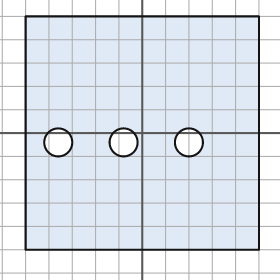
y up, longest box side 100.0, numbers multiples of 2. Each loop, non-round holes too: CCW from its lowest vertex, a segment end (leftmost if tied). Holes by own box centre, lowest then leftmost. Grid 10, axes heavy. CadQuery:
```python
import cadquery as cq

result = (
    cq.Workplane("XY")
    .moveTo(-50.0, -50.0)
    .lineTo(50.0, -50.0)
    .lineTo(50.0, 50.0)
    .lineTo(-50.0, 50.0)
    .close()
    .moveTo(-36.0, -4.0)
    .circle(6.0)
    .moveTo(-8.0, -4.0)
    .circle(6.0)
    .moveTo(20.0, -4.0)
    .circle(6.0)
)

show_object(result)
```